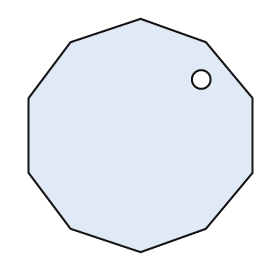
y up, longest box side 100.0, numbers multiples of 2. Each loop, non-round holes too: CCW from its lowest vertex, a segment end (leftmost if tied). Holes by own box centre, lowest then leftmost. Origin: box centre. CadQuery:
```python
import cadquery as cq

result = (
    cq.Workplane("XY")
    .moveTo(0.0, -50.0)
    .lineTo(28.0, -40.0)
    .lineTo(48.0, -16.0)
    .lineTo(48.0, 16.0)
    .lineTo(28.0, 40.0)
    .lineTo(0.0, 50.0)
    .lineTo(-30.0, 40.0)
    .lineTo(-48.0, 16.0)
    .lineTo(-48.0, -16.0)
    .lineTo(-30.0, -40.0)
    .close()
    .moveTo(26.0, 24.0)
    .circle(4.0)
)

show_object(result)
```